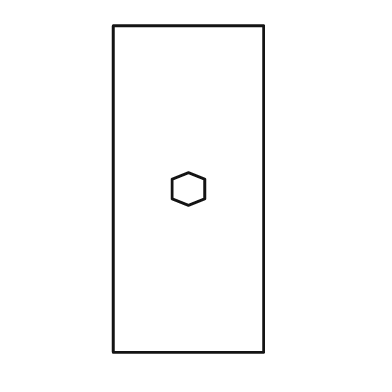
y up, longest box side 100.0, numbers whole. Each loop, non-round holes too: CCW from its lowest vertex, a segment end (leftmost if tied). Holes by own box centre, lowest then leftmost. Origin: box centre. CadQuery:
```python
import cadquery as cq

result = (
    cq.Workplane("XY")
    .moveTo(-23.0, -50.0)
    .lineTo(23.0, -50.0)
    .lineTo(23.0, 50.0)
    .lineTo(-23.0, 50.0)
    .close()
    .moveTo(0.0, -5.0)
    .lineTo(5.0, -3.0)
    .lineTo(5.0, 3.0)
    .lineTo(0.0, 5.0)
    .lineTo(-5.0, 3.0)
    .lineTo(-5.0, -3.0)
    .close()
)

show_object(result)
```